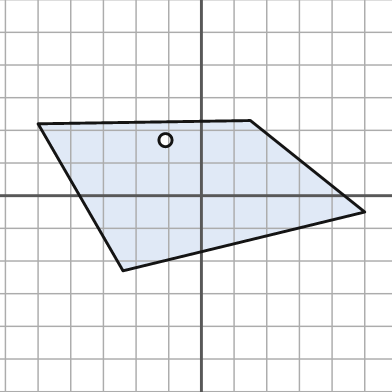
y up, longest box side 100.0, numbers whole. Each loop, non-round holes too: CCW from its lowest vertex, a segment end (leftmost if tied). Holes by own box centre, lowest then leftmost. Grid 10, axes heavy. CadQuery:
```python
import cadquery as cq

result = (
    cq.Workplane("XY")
    .moveTo(-24.0, -23.0)
    .lineTo(50.0, -5.0)
    .lineTo(15.0, 23.0)
    .lineTo(-50.0, 22.0)
    .close()
    .moveTo(-11.0, 17.0)
    .circle(2.0)
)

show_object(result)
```